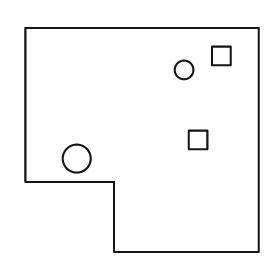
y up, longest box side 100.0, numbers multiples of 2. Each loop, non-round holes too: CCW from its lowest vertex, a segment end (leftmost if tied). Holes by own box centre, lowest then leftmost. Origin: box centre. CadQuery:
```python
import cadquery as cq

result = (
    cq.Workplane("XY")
    .moveTo(-12.0, -48.0)
    .lineTo(50.0, -48.0)
    .lineTo(50.0, 48.0)
    .lineTo(-50.0, 48.0)
    .lineTo(-50.0, -18.0)
    .lineTo(-12.0, -18.0)
    .close()
    .moveTo(-28.0, -8.0)
    .circle(6.0)
    .moveTo(20.0, -4.0)
    .lineTo(28.0, -4.0)
    .lineTo(28.0, 4.0)
    .lineTo(20.0, 4.0)
    .close()
    .moveTo(18.0, 30.0)
    .circle(4.0)
    .moveTo(30.0, 32.0)
    .lineTo(38.0, 32.0)
    .lineTo(38.0, 40.0)
    .lineTo(30.0, 40.0)
    .close()
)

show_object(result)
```